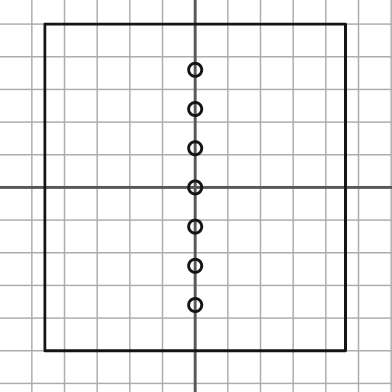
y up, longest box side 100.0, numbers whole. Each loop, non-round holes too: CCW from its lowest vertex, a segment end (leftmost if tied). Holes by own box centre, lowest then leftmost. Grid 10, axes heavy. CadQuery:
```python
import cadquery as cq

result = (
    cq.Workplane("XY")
    .moveTo(-46.0, -50.0)
    .lineTo(46.0, -50.0)
    .lineTo(46.0, 50.0)
    .lineTo(-46.0, 50.0)
    .close()
    .moveTo(0.0, -36.0)
    .circle(2.0)
    .moveTo(0.0, -24.0)
    .circle(2.0)
    .moveTo(0.0, -12.0)
    .circle(2.0)
    .moveTo(0.0, 0.0)
    .circle(2.0)
    .moveTo(0.0, 12.0)
    .circle(2.0)
    .moveTo(0.0, 24.0)
    .circle(2.0)
    .moveTo(0.0, 36.0)
    .circle(2.0)
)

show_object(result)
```